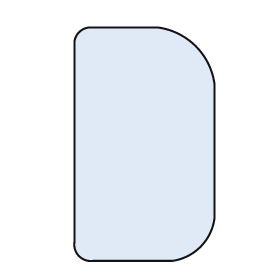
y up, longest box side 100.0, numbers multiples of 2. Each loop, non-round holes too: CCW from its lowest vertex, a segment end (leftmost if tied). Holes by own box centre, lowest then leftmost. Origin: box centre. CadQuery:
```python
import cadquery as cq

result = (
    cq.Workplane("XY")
    .moveTo(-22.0, -50.0)
    .lineTo(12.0, -50.0)
    .threePointArc((24.0, -44.0), (30.0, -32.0))
    .lineTo(30.0, 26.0)
    .threePointArc((22.0, 42.0), (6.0, 50.0))
    .lineTo(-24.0, 50.0)
    .threePointArc((-28.0, 48.0), (-30.0, 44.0))
    .lineTo(-30.0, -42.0)
    .threePointArc((-28.0, -48.0), (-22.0, -50.0))
    .close()
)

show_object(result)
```